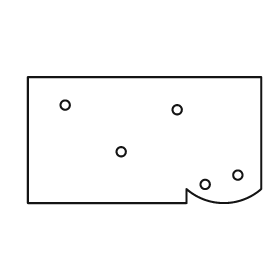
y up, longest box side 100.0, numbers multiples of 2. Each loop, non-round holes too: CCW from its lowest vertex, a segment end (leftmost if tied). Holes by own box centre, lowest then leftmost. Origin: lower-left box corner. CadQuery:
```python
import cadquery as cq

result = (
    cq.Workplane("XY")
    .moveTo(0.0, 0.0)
    .lineTo(68.0, 0.0)
    .lineTo(68.0, 6.0)
    .threePointArc((84.0, 0.0), (100.0, 6.0))
    .lineTo(100.0, 54.0)
    .lineTo(0.0, 54.0)
    .close()
    .moveTo(76.0, 8.0)
    .circle(2.0)
    .moveTo(90.0, 12.0)
    .circle(2.0)
    .moveTo(40.0, 22.0)
    .circle(2.0)
    .moveTo(64.0, 40.0)
    .circle(2.0)
    .moveTo(16.0, 42.0)
    .circle(2.0)
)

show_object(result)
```